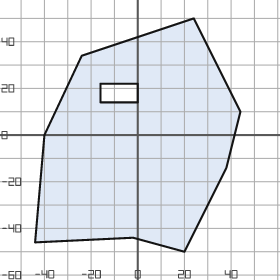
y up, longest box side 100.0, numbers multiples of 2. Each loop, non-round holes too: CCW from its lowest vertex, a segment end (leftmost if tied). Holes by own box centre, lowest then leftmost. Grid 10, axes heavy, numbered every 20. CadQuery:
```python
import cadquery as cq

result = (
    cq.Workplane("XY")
    .moveTo(20.0, -50.0)
    .lineTo(38.0, -14.0)
    .lineTo(44.0, 10.0)
    .lineTo(24.0, 50.0)
    .lineTo(-24.0, 34.0)
    .lineTo(-40.0, 0.0)
    .lineTo(-44.0, -46.0)
    .lineTo(-2.0, -44.0)
    .close()
    .moveTo(-16.0, 14.0)
    .lineTo(0.0, 14.0)
    .lineTo(0.0, 22.0)
    .lineTo(-16.0, 22.0)
    .close()
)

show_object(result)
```